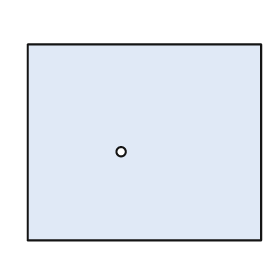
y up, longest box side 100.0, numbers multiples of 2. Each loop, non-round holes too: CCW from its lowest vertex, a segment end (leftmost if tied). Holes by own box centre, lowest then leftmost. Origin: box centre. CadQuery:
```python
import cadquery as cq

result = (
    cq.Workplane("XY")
    .moveTo(-50.0, -42.0)
    .lineTo(50.0, -42.0)
    .lineTo(50.0, 42.0)
    .lineTo(-50.0, 42.0)
    .close()
    .moveTo(-10.0, -4.0)
    .circle(2.0)
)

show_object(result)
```